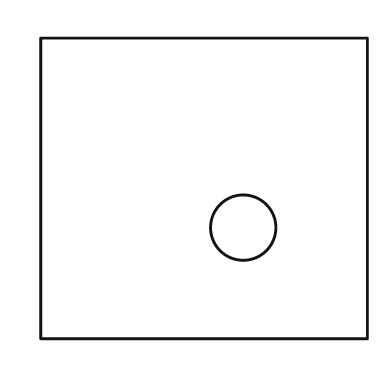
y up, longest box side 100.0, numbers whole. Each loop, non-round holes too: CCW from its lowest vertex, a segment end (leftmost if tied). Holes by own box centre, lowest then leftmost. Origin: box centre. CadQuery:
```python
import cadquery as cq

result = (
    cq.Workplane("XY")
    .moveTo(-50.0, -46.0)
    .lineTo(50.0, -46.0)
    .lineTo(50.0, 46.0)
    .lineTo(-50.0, 46.0)
    .close()
    .moveTo(12.0, -12.0)
    .circle(10.0)
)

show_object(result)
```